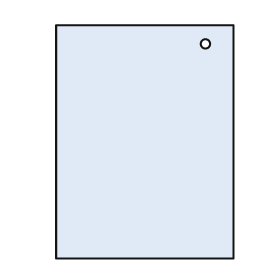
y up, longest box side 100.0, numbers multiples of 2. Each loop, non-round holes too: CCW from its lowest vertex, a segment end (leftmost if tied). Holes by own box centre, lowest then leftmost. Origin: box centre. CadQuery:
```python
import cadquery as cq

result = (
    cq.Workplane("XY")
    .moveTo(-38.0, -50.0)
    .lineTo(38.0, -50.0)
    .lineTo(38.0, 50.0)
    .lineTo(-38.0, 50.0)
    .close()
    .moveTo(26.0, 42.0)
    .circle(2.0)
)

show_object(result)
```